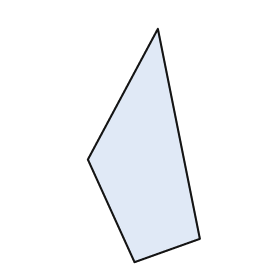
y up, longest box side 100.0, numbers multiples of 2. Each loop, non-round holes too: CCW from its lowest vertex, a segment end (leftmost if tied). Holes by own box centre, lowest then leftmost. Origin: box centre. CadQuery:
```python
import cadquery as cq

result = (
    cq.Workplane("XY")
    .moveTo(-4.0, -50.0)
    .lineTo(24.0, -40.0)
    .lineTo(6.0, 50.0)
    .lineTo(-24.0, -6.0)
    .close()
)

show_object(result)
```